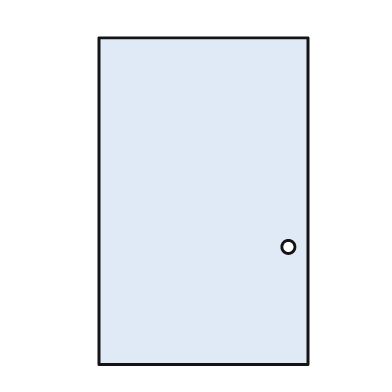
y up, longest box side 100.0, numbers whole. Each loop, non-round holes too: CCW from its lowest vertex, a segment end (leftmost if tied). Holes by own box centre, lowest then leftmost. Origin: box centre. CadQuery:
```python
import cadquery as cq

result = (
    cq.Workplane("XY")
    .moveTo(-32.0, -50.0)
    .lineTo(32.0, -50.0)
    .lineTo(32.0, 50.0)
    .lineTo(-32.0, 50.0)
    .close()
    .moveTo(26.0, -14.0)
    .circle(2.0)
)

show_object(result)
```